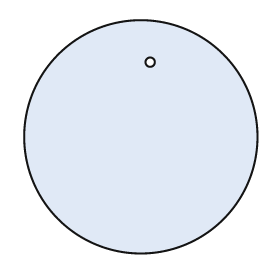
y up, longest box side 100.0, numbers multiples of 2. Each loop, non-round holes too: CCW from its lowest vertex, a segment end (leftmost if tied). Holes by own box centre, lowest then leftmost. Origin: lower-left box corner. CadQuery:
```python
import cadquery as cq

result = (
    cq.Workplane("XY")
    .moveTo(50.0, 50.0)
    .circle(50.0)
    .moveTo(54.0, 82.0)
    .circle(2.0)
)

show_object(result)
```